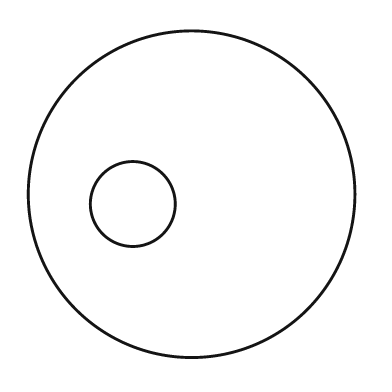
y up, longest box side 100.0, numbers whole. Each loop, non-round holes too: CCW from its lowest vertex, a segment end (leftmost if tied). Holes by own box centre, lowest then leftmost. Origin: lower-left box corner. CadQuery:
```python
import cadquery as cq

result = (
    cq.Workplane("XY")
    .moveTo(50.0, 50.0)
    .circle(50.0)
    .moveTo(32.0, 47.0)
    .circle(13.0)
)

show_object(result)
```